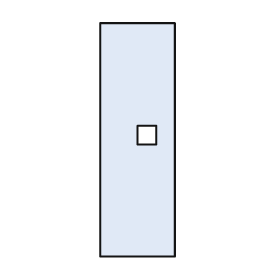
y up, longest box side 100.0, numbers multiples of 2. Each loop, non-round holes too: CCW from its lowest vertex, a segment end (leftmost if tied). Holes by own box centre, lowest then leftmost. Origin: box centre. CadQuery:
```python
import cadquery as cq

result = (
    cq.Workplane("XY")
    .moveTo(-16.0, -50.0)
    .lineTo(16.0, -50.0)
    .lineTo(16.0, 50.0)
    .lineTo(-16.0, 50.0)
    .close()
    .moveTo(0.0, -2.0)
    .lineTo(8.0, -2.0)
    .lineTo(8.0, 6.0)
    .lineTo(0.0, 6.0)
    .close()
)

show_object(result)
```